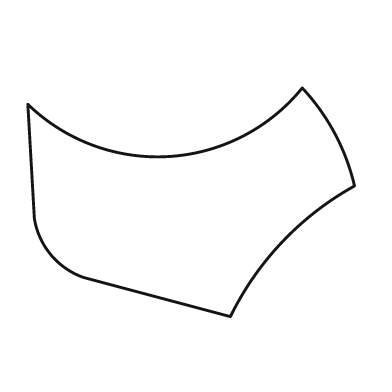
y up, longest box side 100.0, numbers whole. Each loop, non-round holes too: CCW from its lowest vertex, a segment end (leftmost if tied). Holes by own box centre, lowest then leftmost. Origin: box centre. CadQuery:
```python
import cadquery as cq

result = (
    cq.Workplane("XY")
    .moveTo(12.0, -35.0)
    .threePointArc((28.0, -12.0), (50.0, 5.0))
    .threePointArc((44.0, 21.0), (34.0, 35.0))
    .threePointArc((-7.0, 14.0), (-50.0, 30.0))
    .lineTo(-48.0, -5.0)
    .threePointArc((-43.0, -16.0), (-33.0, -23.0))
    .close()
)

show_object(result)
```